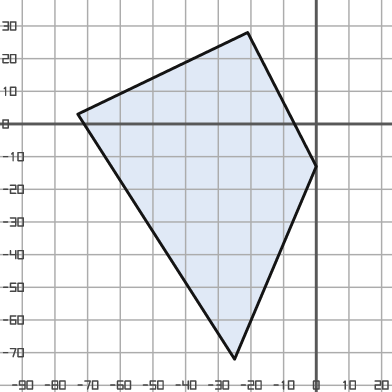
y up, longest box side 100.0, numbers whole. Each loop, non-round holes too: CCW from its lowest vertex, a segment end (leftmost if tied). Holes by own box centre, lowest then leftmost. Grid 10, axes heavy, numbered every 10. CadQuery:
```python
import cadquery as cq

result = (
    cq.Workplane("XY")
    .moveTo(-25.0, -72.0)
    .lineTo(0.0, -13.0)
    .lineTo(-21.0, 28.0)
    .lineTo(-73.0, 3.0)
    .close()
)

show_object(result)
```